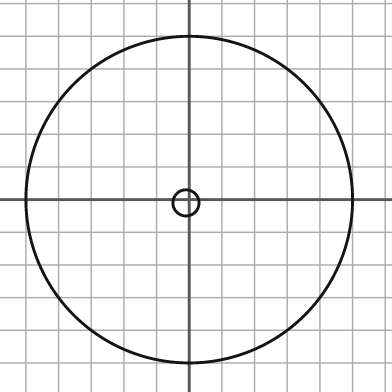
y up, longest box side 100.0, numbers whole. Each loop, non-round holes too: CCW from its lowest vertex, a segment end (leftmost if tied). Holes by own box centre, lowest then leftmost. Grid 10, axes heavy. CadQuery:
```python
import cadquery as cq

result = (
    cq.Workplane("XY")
    .moveTo(0.0, 0.0)
    .circle(50.0)
    .moveTo(-1.0, -1.0)
    .circle(4.0)
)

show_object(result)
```